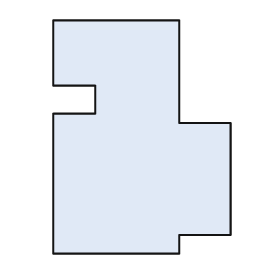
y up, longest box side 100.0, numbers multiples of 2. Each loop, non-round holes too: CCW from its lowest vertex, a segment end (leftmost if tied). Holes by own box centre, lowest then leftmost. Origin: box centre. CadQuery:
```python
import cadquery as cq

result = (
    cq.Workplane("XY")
    .moveTo(-38.0, -50.0)
    .lineTo(16.0, -50.0)
    .lineTo(16.0, -42.0)
    .lineTo(38.0, -42.0)
    .lineTo(38.0, 6.0)
    .lineTo(16.0, 6.0)
    .lineTo(16.0, 50.0)
    .lineTo(-38.0, 50.0)
    .lineTo(-38.0, 22.0)
    .lineTo(-20.0, 22.0)
    .lineTo(-20.0, 10.0)
    .lineTo(-38.0, 10.0)
    .close()
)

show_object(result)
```